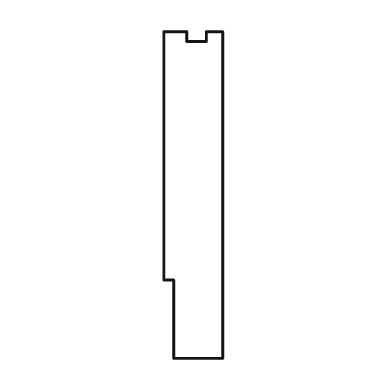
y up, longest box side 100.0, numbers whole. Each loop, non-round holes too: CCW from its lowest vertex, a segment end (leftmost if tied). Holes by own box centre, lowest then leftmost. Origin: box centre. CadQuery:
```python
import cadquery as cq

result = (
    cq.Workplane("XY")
    .moveTo(-6.0, -50.0)
    .lineTo(9.0, -50.0)
    .lineTo(9.0, 50.0)
    .lineTo(4.0, 50.0)
    .lineTo(4.0, 47.0)
    .lineTo(-2.0, 47.0)
    .lineTo(-2.0, 50.0)
    .lineTo(-9.0, 50.0)
    .lineTo(-9.0, -26.0)
    .lineTo(-6.0, -26.0)
    .close()
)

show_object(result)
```